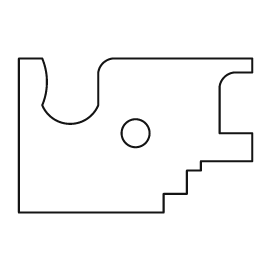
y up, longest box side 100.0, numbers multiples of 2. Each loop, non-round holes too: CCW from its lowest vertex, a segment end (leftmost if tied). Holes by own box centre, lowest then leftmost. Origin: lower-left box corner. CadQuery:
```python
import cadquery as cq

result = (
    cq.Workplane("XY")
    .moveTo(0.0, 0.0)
    .lineTo(62.0, 0.0)
    .lineTo(62.0, 8.0)
    .lineTo(72.0, 8.0)
    .lineTo(72.0, 18.0)
    .lineTo(78.0, 18.0)
    .lineTo(78.0, 22.0)
    .lineTo(100.0, 22.0)
    .lineTo(100.0, 34.0)
    .lineTo(86.0, 34.0)
    .lineTo(86.0, 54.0)
    .threePointArc((88.0, 58.0), (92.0, 60.0))
    .lineTo(100.0, 60.0)
    .lineTo(100.0, 66.0)
    .lineTo(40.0, 66.0)
    .threePointArc((36.0, 64.0), (34.0, 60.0))
    .lineTo(34.0, 46.0)
    .threePointArc((22.0, 38.0), (10.0, 46.0))
    .threePointArc((12.0, 56.0), (10.0, 66.0))
    .lineTo(0.0, 66.0)
    .close()
    .moveTo(50.0, 34.0)
    .circle(6.0)
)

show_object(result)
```